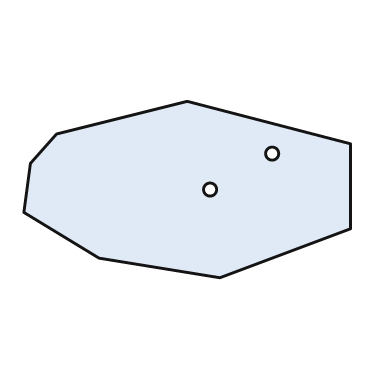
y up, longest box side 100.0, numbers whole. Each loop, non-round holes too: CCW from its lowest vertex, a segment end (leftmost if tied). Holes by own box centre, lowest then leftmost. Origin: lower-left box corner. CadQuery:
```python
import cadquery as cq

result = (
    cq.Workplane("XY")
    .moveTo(60.0, 0.0)
    .lineTo(100.0, 15.0)
    .lineTo(100.0, 41.0)
    .lineTo(50.0, 54.0)
    .lineTo(10.0, 44.0)
    .lineTo(2.0, 35.0)
    .lineTo(0.0, 20.0)
    .lineTo(23.0, 6.0)
    .close()
    .moveTo(57.0, 27.0)
    .circle(2.0)
    .moveTo(76.0, 38.0)
    .circle(2.0)
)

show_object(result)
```